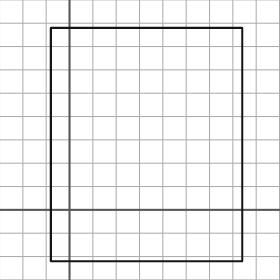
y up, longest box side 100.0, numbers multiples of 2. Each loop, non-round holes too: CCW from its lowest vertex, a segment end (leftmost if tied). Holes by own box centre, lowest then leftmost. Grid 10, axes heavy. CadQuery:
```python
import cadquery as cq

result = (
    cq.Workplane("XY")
    .moveTo(-8.0, -22.0)
    .lineTo(74.0, -22.0)
    .lineTo(74.0, 78.0)
    .lineTo(-8.0, 78.0)
    .close()
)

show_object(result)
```